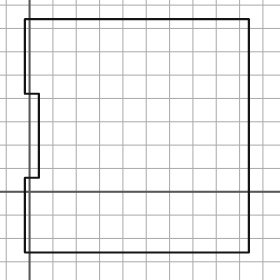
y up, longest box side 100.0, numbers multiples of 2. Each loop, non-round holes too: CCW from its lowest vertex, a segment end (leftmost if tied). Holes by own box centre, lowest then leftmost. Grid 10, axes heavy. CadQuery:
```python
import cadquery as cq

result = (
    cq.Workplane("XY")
    .moveTo(-2.0, -26.0)
    .lineTo(94.0, -26.0)
    .lineTo(94.0, 74.0)
    .lineTo(-2.0, 74.0)
    .lineTo(-2.0, 42.0)
    .lineTo(4.0, 42.0)
    .lineTo(4.0, 6.0)
    .lineTo(-2.0, 6.0)
    .close()
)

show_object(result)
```